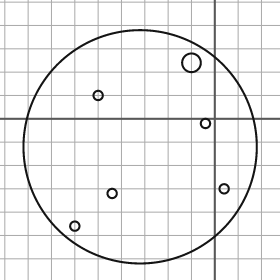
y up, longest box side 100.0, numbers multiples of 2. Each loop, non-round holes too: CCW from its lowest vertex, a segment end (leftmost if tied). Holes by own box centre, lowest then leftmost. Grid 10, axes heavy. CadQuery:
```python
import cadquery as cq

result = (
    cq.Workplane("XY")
    .moveTo(-32.0, -12.0)
    .circle(50.0)
    .moveTo(-60.0, -46.0)
    .circle(2.0)
    .moveTo(-44.0, -32.0)
    .circle(2.0)
    .moveTo(4.0, -30.0)
    .circle(2.0)
    .moveTo(-4.0, -2.0)
    .circle(2.0)
    .moveTo(-50.0, 10.0)
    .circle(2.0)
    .moveTo(-10.0, 24.0)
    .circle(4.0)
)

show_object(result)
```